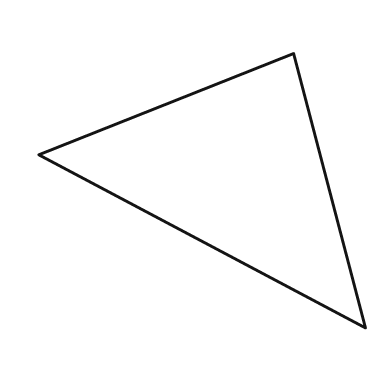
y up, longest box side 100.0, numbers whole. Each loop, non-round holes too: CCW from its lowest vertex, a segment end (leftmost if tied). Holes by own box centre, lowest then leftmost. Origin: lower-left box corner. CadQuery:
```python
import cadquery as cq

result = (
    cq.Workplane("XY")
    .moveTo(100.0, 0.0)
    .lineTo(78.0, 84.0)
    .lineTo(0.0, 53.0)
    .close()
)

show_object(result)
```